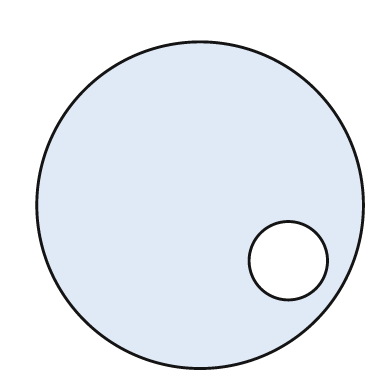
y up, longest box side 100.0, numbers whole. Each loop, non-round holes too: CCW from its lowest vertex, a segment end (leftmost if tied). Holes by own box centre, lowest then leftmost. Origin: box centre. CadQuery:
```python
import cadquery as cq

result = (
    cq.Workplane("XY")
    .moveTo(0.0, 0.0)
    .circle(50.0)
    .moveTo(27.0, -17.0)
    .circle(12.0)
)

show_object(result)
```